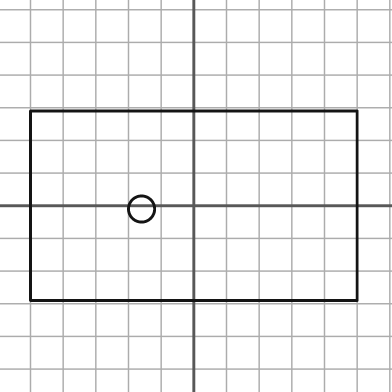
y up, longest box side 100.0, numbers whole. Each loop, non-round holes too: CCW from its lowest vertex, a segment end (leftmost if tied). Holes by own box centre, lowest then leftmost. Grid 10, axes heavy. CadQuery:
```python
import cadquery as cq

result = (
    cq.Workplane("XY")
    .moveTo(-50.0, -29.0)
    .lineTo(50.0, -29.0)
    .lineTo(50.0, 29.0)
    .lineTo(-50.0, 29.0)
    .close()
    .moveTo(-16.0, -1.0)
    .circle(4.0)
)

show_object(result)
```